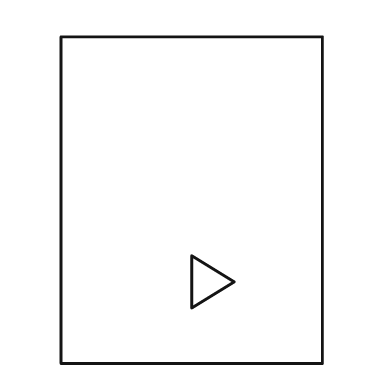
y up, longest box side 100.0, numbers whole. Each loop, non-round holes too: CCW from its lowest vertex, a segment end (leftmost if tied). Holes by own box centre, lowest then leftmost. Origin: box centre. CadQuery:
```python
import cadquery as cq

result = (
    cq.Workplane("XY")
    .moveTo(-40.0, -50.0)
    .lineTo(40.0, -50.0)
    .lineTo(40.0, 50.0)
    .lineTo(-40.0, 50.0)
    .close()
    .moveTo(0.0, -33.0)
    .lineTo(13.0, -25.0)
    .lineTo(0.0, -17.0)
    .close()
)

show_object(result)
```